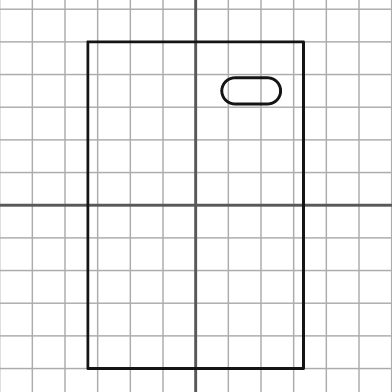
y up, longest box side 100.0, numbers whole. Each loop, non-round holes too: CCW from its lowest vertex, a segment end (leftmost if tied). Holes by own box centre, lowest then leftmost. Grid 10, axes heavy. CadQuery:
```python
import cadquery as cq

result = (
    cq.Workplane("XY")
    .moveTo(-33.0, -50.0)
    .lineTo(33.0, -50.0)
    .lineTo(33.0, 50.0)
    .lineTo(-33.0, 50.0)
    .close()
    .moveTo(12.0, 31.0)
    .lineTo(22.0, 31.0)
    .threePointArc((26.0, 35.0), (22.0, 39.0))
    .lineTo(12.0, 39.0)
    .threePointArc((8.0, 35.0), (12.0, 31.0))
    .close()
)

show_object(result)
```